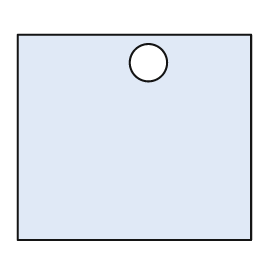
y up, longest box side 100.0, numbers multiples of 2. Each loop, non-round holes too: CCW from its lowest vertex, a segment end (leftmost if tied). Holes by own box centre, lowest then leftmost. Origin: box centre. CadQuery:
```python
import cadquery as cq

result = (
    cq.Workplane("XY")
    .moveTo(-50.0, -44.0)
    .lineTo(50.0, -44.0)
    .lineTo(50.0, 44.0)
    .lineTo(-50.0, 44.0)
    .close()
    .moveTo(6.0, 32.0)
    .circle(8.0)
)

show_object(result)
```